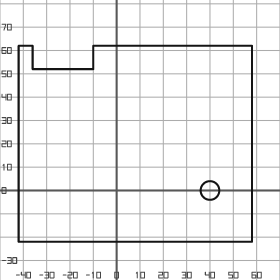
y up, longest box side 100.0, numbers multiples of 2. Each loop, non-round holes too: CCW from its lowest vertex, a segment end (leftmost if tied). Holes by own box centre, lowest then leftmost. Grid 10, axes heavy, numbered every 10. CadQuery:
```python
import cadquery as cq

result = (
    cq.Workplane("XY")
    .moveTo(-42.0, -22.0)
    .lineTo(58.0, -22.0)
    .lineTo(58.0, 62.0)
    .lineTo(-10.0, 62.0)
    .lineTo(-10.0, 52.0)
    .lineTo(-36.0, 52.0)
    .lineTo(-36.0, 62.0)
    .lineTo(-42.0, 62.0)
    .close()
    .moveTo(40.0, 0.0)
    .circle(4.0)
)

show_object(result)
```